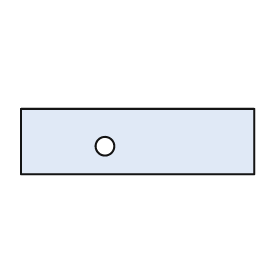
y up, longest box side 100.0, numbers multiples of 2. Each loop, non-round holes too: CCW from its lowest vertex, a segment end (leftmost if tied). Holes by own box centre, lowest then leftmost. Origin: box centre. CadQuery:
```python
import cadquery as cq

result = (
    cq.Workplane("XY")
    .moveTo(-50.0, -14.0)
    .lineTo(50.0, -14.0)
    .lineTo(50.0, 14.0)
    .lineTo(-50.0, 14.0)
    .close()
    .moveTo(-14.0, -2.0)
    .circle(4.0)
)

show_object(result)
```